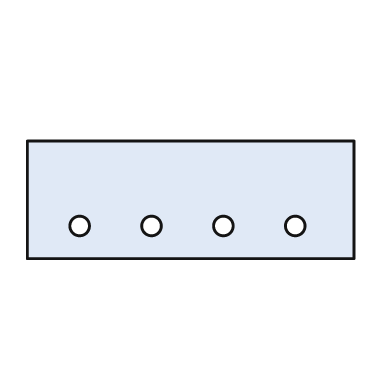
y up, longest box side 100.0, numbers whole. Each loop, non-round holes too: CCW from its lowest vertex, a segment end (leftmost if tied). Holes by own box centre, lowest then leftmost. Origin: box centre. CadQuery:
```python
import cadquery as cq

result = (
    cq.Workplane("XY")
    .moveTo(-50.0, -18.0)
    .lineTo(50.0, -18.0)
    .lineTo(50.0, 18.0)
    .lineTo(-50.0, 18.0)
    .close()
    .moveTo(-34.0, -8.0)
    .circle(3.0)
    .moveTo(-12.0, -8.0)
    .circle(3.0)
    .moveTo(10.0, -8.0)
    .circle(3.0)
    .moveTo(32.0, -8.0)
    .circle(3.0)
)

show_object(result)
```